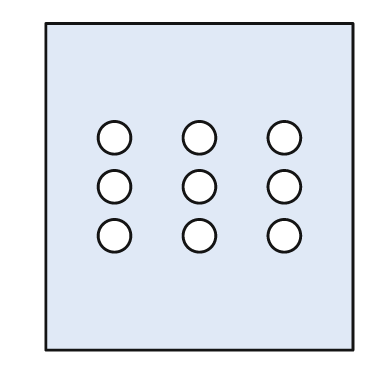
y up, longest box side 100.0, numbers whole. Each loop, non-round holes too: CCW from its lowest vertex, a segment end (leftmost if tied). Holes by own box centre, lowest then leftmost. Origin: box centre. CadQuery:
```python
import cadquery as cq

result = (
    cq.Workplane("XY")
    .moveTo(-47.0, -50.0)
    .lineTo(47.0, -50.0)
    .lineTo(47.0, 50.0)
    .lineTo(-47.0, 50.0)
    .close()
    .moveTo(-26.0, -15.0)
    .circle(5.0)
    .moveTo(0.0, -15.0)
    .circle(5.0)
    .moveTo(26.0, -15.0)
    .circle(5.0)
    .moveTo(-26.0, 0.0)
    .circle(5.0)
    .moveTo(0.0, 0.0)
    .circle(5.0)
    .moveTo(26.0, 0.0)
    .circle(5.0)
    .moveTo(-26.0, 15.0)
    .circle(5.0)
    .moveTo(0.0, 15.0)
    .circle(5.0)
    .moveTo(26.0, 15.0)
    .circle(5.0)
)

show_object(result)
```